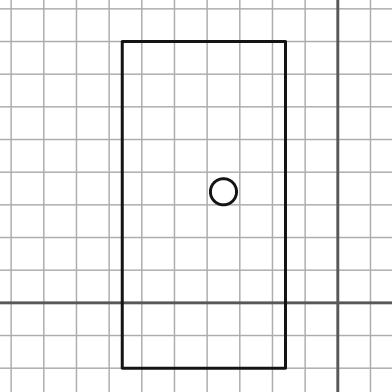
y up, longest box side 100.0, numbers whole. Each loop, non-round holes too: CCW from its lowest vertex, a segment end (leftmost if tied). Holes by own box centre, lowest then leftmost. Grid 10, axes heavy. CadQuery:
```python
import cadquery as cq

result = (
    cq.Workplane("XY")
    .moveTo(-66.0, -20.0)
    .lineTo(-16.0, -20.0)
    .lineTo(-16.0, 80.0)
    .lineTo(-66.0, 80.0)
    .close()
    .moveTo(-35.0, 34.0)
    .circle(4.0)
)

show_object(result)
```